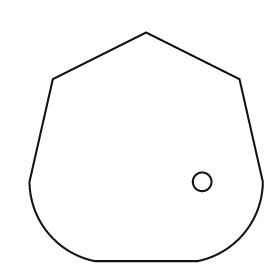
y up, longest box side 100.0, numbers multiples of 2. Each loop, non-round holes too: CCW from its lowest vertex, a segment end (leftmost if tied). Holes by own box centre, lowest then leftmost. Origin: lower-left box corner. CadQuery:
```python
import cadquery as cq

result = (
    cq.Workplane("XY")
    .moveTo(28.0, 0.0)
    .lineTo(72.0, 0.0)
    .threePointArc((92.0, 12.0), (100.0, 34.0))
    .lineTo(90.0, 78.0)
    .lineTo(50.0, 98.0)
    .lineTo(10.0, 78.0)
    .lineTo(0.0, 34.0)
    .threePointArc((8.0, 12.0), (28.0, 0.0))
    .close()
    .moveTo(74.0, 34.0)
    .circle(4.0)
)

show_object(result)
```